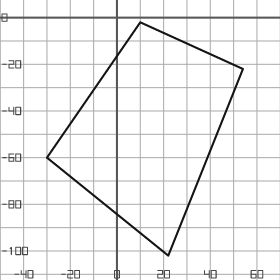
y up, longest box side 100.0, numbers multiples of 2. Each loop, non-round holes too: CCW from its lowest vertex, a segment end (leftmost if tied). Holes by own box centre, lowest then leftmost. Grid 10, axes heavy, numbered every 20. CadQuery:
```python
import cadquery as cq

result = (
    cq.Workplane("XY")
    .moveTo(22.0, -102.0)
    .lineTo(54.0, -22.0)
    .lineTo(10.0, -2.0)
    .lineTo(-30.0, -60.0)
    .close()
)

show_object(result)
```